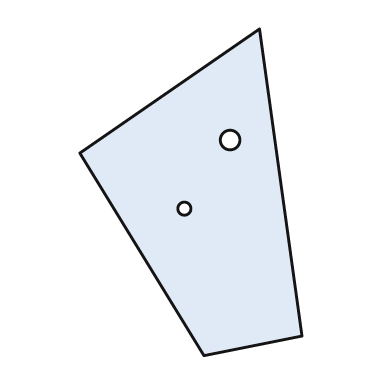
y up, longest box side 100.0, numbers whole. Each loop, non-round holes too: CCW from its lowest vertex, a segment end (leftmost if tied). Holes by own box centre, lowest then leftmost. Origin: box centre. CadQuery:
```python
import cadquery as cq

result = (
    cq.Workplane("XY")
    .moveTo(4.0, -50.0)
    .lineTo(34.0, -44.0)
    .lineTo(21.0, 50.0)
    .lineTo(-34.0, 12.0)
    .close()
    .moveTo(-2.0, -5.0)
    .circle(2.0)
    .moveTo(12.0, 16.0)
    .circle(3.0)
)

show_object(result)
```